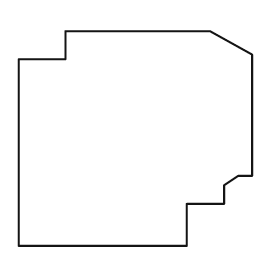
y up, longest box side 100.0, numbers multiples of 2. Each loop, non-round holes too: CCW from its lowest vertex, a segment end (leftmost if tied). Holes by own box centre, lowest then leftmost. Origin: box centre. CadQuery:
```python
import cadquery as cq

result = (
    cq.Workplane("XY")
    .moveTo(-50.0, -46.0)
    .lineTo(22.0, -46.0)
    .lineTo(22.0, -28.0)
    .lineTo(38.0, -28.0)
    .lineTo(38.0, -20.0)
    .lineTo(44.0, -16.0)
    .lineTo(50.0, -16.0)
    .lineTo(50.0, 36.0)
    .lineTo(32.0, 46.0)
    .lineTo(-30.0, 46.0)
    .lineTo(-30.0, 34.0)
    .lineTo(-50.0, 34.0)
    .close()
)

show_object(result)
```